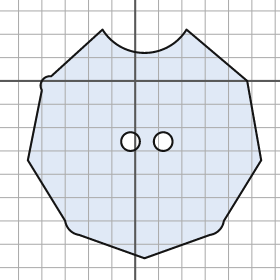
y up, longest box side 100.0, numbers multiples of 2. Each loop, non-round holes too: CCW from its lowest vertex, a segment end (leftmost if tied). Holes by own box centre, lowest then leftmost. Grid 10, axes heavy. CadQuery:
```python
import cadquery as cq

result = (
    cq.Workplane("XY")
    .moveTo(4.0, -76.0)
    .lineTo(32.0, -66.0)
    .threePointArc((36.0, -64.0), (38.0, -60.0))
    .lineTo(54.0, -34.0)
    .lineTo(48.0, 0.0)
    .lineTo(22.0, 22.0)
    .threePointArc((4.0, 12.0), (-14.0, 22.0))
    .lineTo(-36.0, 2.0)
    .threePointArc((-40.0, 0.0), (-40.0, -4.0))
    .lineTo(-46.0, -34.0)
    .lineTo(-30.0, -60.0)
    .threePointArc((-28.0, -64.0), (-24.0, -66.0))
    .close()
    .moveTo(-2.0, -26.0)
    .circle(4.0)
    .moveTo(12.0, -26.0)
    .circle(4.0)
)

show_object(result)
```